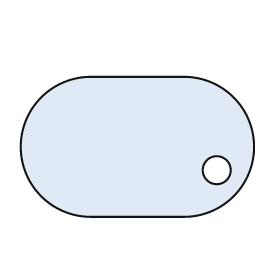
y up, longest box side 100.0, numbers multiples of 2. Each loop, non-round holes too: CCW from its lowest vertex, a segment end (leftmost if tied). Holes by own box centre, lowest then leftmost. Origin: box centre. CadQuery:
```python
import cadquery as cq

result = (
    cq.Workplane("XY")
    .moveTo(-20.0, -30.0)
    .lineTo(20.0, -30.0)
    .threePointArc((50.0, 0.0), (20.0, 30.0))
    .lineTo(-20.0, 30.0)
    .threePointArc((-50.0, 0.0), (-20.0, -30.0))
    .close()
    .moveTo(34.0, -10.0)
    .circle(6.0)
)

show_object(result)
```